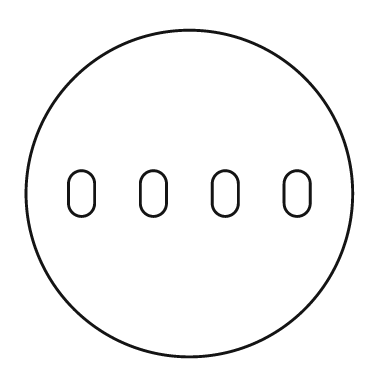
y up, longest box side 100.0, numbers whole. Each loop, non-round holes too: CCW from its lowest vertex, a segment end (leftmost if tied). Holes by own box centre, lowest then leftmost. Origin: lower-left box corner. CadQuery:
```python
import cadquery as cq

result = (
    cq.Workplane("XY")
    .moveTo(50.0, 50.0)
    .circle(50.0)
    .moveTo(13.0, 47.0)
    .threePointArc((17.0, 43.0), (21.0, 47.0))
    .lineTo(21.0, 53.0)
    .threePointArc((17.0, 57.0), (13.0, 53.0))
    .close()
    .moveTo(35.0, 47.0)
    .threePointArc((39.0, 43.0), (43.0, 47.0))
    .lineTo(43.0, 53.0)
    .threePointArc((39.0, 57.0), (35.0, 53.0))
    .close()
    .moveTo(57.0, 47.0)
    .threePointArc((61.0, 43.0), (65.0, 47.0))
    .lineTo(65.0, 53.0)
    .threePointArc((61.0, 57.0), (57.0, 53.0))
    .close()
    .moveTo(79.0, 47.0)
    .threePointArc((83.0, 43.0), (87.0, 47.0))
    .lineTo(87.0, 53.0)
    .threePointArc((83.0, 57.0), (79.0, 53.0))
    .close()
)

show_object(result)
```